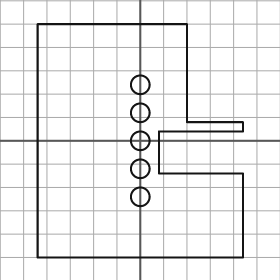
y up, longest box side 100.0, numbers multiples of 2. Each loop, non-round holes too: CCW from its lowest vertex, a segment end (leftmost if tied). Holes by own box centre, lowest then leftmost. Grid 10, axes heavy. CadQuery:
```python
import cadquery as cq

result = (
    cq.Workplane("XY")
    .moveTo(-44.0, -50.0)
    .lineTo(44.0, -50.0)
    .lineTo(44.0, -14.0)
    .lineTo(8.0, -14.0)
    .lineTo(8.0, 4.0)
    .lineTo(44.0, 4.0)
    .lineTo(44.0, 8.0)
    .lineTo(20.0, 8.0)
    .lineTo(20.0, 50.0)
    .lineTo(-44.0, 50.0)
    .close()
    .moveTo(0.0, -24.0)
    .circle(4.0)
    .moveTo(0.0, -12.0)
    .circle(4.0)
    .moveTo(0.0, 0.0)
    .circle(4.0)
    .moveTo(0.0, 12.0)
    .circle(4.0)
    .moveTo(0.0, 24.0)
    .circle(4.0)
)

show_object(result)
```